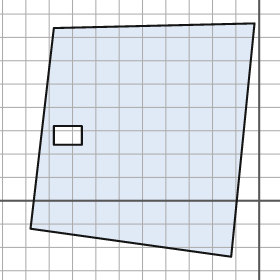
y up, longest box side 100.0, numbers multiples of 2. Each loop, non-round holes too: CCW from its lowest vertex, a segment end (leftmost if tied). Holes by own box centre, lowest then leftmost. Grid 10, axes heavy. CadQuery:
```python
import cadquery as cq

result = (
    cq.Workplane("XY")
    .moveTo(-12.0, -24.0)
    .lineTo(-2.0, 76.0)
    .lineTo(-88.0, 74.0)
    .lineTo(-98.0, -12.0)
    .close()
    .moveTo(-88.0, 24.0)
    .lineTo(-76.0, 24.0)
    .lineTo(-76.0, 32.0)
    .lineTo(-88.0, 32.0)
    .close()
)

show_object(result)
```